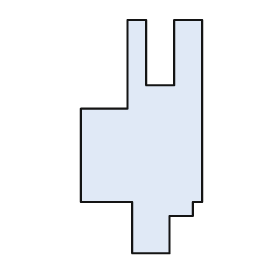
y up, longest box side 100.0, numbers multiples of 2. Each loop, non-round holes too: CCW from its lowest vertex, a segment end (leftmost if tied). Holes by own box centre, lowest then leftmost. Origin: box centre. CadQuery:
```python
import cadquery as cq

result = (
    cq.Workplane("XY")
    .moveTo(-4.0, -50.0)
    .lineTo(12.0, -50.0)
    .lineTo(12.0, -34.0)
    .lineTo(22.0, -34.0)
    .lineTo(22.0, -28.0)
    .lineTo(26.0, -28.0)
    .lineTo(26.0, 50.0)
    .lineTo(14.0, 50.0)
    .lineTo(14.0, 22.0)
    .lineTo(2.0, 22.0)
    .lineTo(2.0, 50.0)
    .lineTo(-6.0, 50.0)
    .lineTo(-6.0, 12.0)
    .lineTo(-26.0, 12.0)
    .lineTo(-26.0, -28.0)
    .lineTo(-4.0, -28.0)
    .close()
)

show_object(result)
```